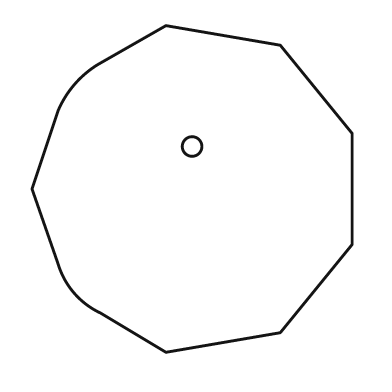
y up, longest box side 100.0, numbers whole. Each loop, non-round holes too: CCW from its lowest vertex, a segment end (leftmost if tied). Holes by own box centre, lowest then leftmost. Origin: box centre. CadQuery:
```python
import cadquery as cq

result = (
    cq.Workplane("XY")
    .moveTo(-8.0, -50.0)
    .lineTo(27.0, -44.0)
    .lineTo(49.0, -17.0)
    .lineTo(49.0, 17.0)
    .lineTo(27.0, 44.0)
    .lineTo(-8.0, 50.0)
    .lineTo(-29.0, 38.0)
    .threePointArc((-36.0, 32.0), (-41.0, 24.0))
    .lineTo(-49.0, 0.0)
    .lineTo(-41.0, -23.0)
    .threePointArc((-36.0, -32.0), (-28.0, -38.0))
    .close()
    .moveTo(0.0, 13.0)
    .circle(3.0)
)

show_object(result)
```